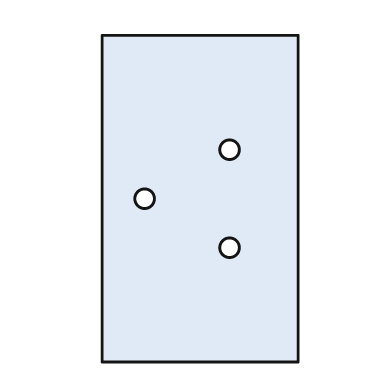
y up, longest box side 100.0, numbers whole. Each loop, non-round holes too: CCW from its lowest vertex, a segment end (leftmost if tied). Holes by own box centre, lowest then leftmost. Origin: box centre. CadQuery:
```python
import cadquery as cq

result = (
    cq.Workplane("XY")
    .moveTo(-30.0, -50.0)
    .lineTo(30.0, -50.0)
    .lineTo(30.0, 50.0)
    .lineTo(-30.0, 50.0)
    .close()
    .moveTo(9.0, -15.0)
    .circle(3.0)
    .moveTo(-17.0, 0.0)
    .circle(3.0)
    .moveTo(9.0, 15.0)
    .circle(3.0)
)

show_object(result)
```